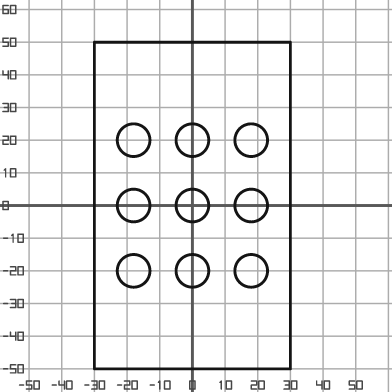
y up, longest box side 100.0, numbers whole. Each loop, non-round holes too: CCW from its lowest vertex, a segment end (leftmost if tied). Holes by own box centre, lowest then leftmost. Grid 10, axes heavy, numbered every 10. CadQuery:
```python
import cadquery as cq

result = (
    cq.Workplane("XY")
    .moveTo(-30.0, -50.0)
    .lineTo(30.0, -50.0)
    .lineTo(30.0, 50.0)
    .lineTo(-30.0, 50.0)
    .close()
    .moveTo(-18.0, -20.0)
    .circle(5.0)
    .moveTo(0.0, -20.0)
    .circle(5.0)
    .moveTo(18.0, -20.0)
    .circle(5.0)
    .moveTo(-18.0, 0.0)
    .circle(5.0)
    .moveTo(0.0, 0.0)
    .circle(5.0)
    .moveTo(18.0, 0.0)
    .circle(5.0)
    .moveTo(-18.0, 20.0)
    .circle(5.0)
    .moveTo(0.0, 20.0)
    .circle(5.0)
    .moveTo(18.0, 20.0)
    .circle(5.0)
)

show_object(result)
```